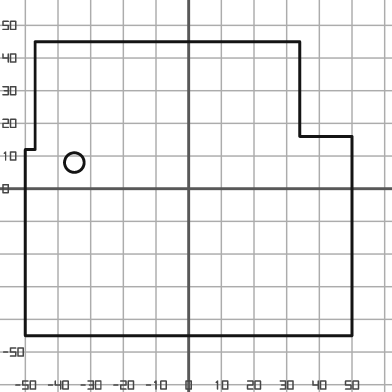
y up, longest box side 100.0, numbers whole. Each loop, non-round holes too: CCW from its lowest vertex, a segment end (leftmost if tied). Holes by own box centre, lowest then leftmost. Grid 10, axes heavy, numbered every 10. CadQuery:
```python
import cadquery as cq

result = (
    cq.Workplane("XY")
    .moveTo(-50.0, -45.0)
    .lineTo(50.0, -45.0)
    .lineTo(50.0, 16.0)
    .lineTo(34.0, 16.0)
    .lineTo(34.0, 45.0)
    .lineTo(-47.0, 45.0)
    .lineTo(-47.0, 12.0)
    .lineTo(-50.0, 12.0)
    .close()
    .moveTo(-35.0, 8.0)
    .circle(3.0)
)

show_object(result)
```